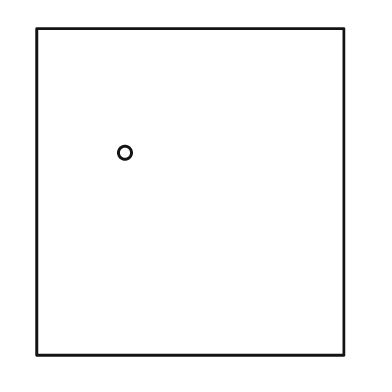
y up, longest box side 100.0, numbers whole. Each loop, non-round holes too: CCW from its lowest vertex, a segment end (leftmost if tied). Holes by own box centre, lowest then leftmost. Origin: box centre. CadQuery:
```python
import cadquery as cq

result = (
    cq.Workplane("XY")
    .moveTo(-47.0, -50.0)
    .lineTo(47.0, -50.0)
    .lineTo(47.0, 50.0)
    .lineTo(-47.0, 50.0)
    .close()
    .moveTo(-20.0, 12.0)
    .circle(2.0)
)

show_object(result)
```